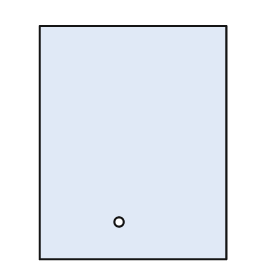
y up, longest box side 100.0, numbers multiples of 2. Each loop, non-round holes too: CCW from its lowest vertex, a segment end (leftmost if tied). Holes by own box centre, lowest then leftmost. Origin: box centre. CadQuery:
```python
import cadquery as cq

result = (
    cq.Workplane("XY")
    .moveTo(-40.0, -50.0)
    .lineTo(40.0, -50.0)
    .lineTo(40.0, 50.0)
    .lineTo(-40.0, 50.0)
    .close()
    .moveTo(-6.0, -34.0)
    .circle(2.0)
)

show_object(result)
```